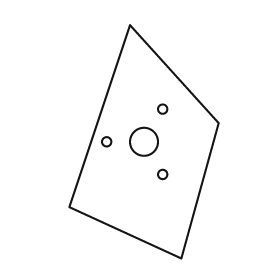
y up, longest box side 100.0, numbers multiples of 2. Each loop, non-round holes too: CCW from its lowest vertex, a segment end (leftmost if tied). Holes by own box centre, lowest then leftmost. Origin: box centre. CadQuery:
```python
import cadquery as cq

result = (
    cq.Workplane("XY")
    .moveTo(16.0, -50.0)
    .lineTo(32.0, 8.0)
    .lineTo(-6.0, 50.0)
    .lineTo(-32.0, -28.0)
    .close()
    .moveTo(8.0, -14.0)
    .circle(2.0)
    .moveTo(-16.0, 0.0)
    .circle(2.0)
    .moveTo(0.0, 0.0)
    .circle(6.0)
    .moveTo(8.0, 14.0)
    .circle(2.0)
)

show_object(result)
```